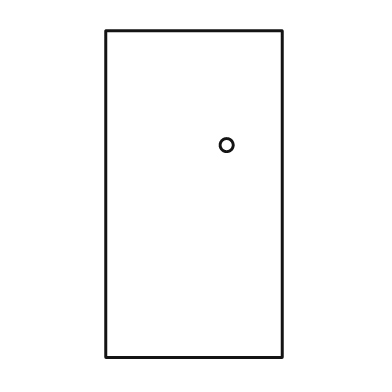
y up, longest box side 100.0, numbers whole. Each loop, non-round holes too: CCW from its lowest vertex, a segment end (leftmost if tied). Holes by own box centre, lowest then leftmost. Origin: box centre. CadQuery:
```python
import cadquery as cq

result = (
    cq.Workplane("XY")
    .moveTo(-27.0, -50.0)
    .lineTo(27.0, -50.0)
    .lineTo(27.0, 50.0)
    .lineTo(-27.0, 50.0)
    .close()
    .moveTo(10.0, 15.0)
    .circle(2.0)
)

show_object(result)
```